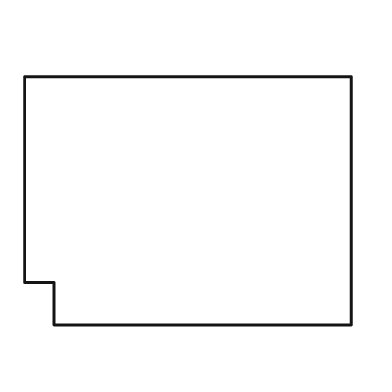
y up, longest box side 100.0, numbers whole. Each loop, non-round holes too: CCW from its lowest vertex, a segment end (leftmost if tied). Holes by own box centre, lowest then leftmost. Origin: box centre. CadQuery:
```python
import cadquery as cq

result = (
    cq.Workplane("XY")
    .moveTo(-41.0, -38.0)
    .lineTo(50.0, -38.0)
    .lineTo(50.0, 38.0)
    .lineTo(-50.0, 38.0)
    .lineTo(-50.0, -25.0)
    .lineTo(-41.0, -25.0)
    .close()
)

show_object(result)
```